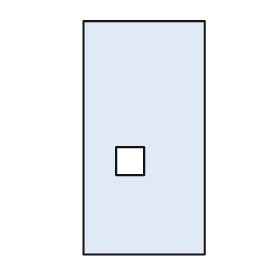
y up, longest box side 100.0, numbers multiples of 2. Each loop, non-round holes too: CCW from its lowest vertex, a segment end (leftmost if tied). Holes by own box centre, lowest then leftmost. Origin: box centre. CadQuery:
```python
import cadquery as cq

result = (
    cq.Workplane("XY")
    .moveTo(-26.0, -50.0)
    .lineTo(26.0, -50.0)
    .lineTo(26.0, 50.0)
    .lineTo(-26.0, 50.0)
    .close()
    .moveTo(-12.0, -16.0)
    .lineTo(0.0, -16.0)
    .lineTo(0.0, -4.0)
    .lineTo(-12.0, -4.0)
    .close()
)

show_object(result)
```